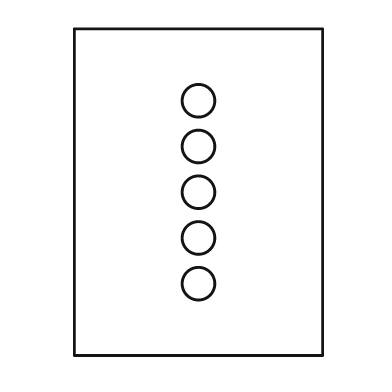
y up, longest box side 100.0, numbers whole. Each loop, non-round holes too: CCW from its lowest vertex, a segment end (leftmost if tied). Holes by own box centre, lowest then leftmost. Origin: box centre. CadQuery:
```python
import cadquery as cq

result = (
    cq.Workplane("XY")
    .moveTo(-38.0, -50.0)
    .lineTo(38.0, -50.0)
    .lineTo(38.0, 50.0)
    .lineTo(-38.0, 50.0)
    .close()
    .moveTo(0.0, -28.0)
    .circle(5.0)
    .moveTo(0.0, -14.0)
    .circle(5.0)
    .moveTo(0.0, 0.0)
    .circle(5.0)
    .moveTo(0.0, 14.0)
    .circle(5.0)
    .moveTo(0.0, 28.0)
    .circle(5.0)
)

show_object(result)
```